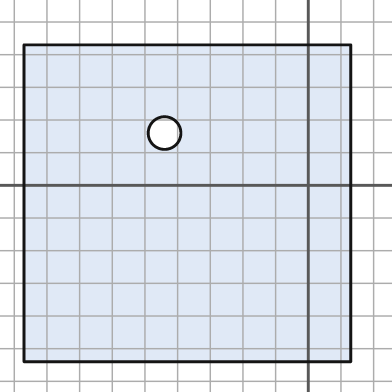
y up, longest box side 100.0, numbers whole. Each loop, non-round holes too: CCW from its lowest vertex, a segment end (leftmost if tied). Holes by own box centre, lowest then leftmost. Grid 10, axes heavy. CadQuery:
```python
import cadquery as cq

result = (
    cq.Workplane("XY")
    .moveTo(-87.0, -54.0)
    .lineTo(13.0, -54.0)
    .lineTo(13.0, 43.0)
    .lineTo(-87.0, 43.0)
    .close()
    .moveTo(-44.0, 16.0)
    .circle(5.0)
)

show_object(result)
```